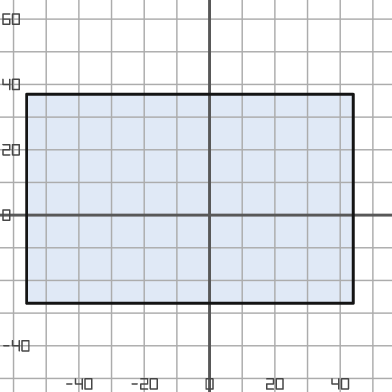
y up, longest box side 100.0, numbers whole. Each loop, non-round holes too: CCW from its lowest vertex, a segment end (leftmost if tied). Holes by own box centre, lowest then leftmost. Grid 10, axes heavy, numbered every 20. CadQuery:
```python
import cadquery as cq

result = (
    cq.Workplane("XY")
    .moveTo(-56.0, -27.0)
    .lineTo(44.0, -27.0)
    .lineTo(44.0, 37.0)
    .lineTo(-56.0, 37.0)
    .close()
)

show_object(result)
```